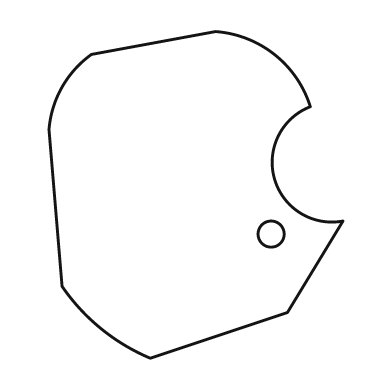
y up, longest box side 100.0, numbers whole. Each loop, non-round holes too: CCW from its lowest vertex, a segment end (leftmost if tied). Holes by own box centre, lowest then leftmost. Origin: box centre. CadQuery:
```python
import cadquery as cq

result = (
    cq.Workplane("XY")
    .moveTo(-14.0, -50.0)
    .lineTo(28.0, -36.0)
    .lineTo(45.0, -8.0)
    .threePointArc((24.0, 5.0), (35.0, 27.0))
    .threePointArc((24.0, 43.0), (6.0, 50.0))
    .lineTo(-32.0, 43.0)
    .threePointArc((-41.0, 33.0), (-45.0, 20.0))
    .lineTo(-41.0, -28.0)
    .threePointArc((-29.0, -41.0), (-14.0, -50.0))
    .close()
    .moveTo(23.0, -12.0)
    .circle(4.0)
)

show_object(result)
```